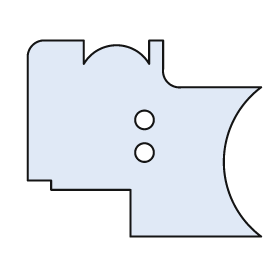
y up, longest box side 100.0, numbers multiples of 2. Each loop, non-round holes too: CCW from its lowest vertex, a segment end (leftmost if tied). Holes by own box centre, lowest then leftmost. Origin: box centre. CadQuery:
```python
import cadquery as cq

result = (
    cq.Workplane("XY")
    .moveTo(-6.0, -42.0)
    .lineTo(50.0, -42.0)
    .threePointArc((34.0, -10.0), (50.0, 22.0))
    .lineTo(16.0, 22.0)
    .threePointArc((10.0, 24.0), (8.0, 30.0))
    .lineTo(8.0, 42.0)
    .lineTo(2.0, 42.0)
    .lineTo(2.0, 32.0)
    .threePointArc((-12.0, 40.0), (-26.0, 32.0))
    .lineTo(-26.0, 42.0)
    .lineTo(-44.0, 42.0)
    .threePointArc((-48.0, 40.0), (-50.0, 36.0))
    .lineTo(-50.0, -18.0)
    .lineTo(-40.0, -18.0)
    .lineTo(-40.0, -22.0)
    .lineTo(-6.0, -22.0)
    .close()
    .moveTo(0.0, -6.0)
    .circle(4.0)
    .moveTo(0.0, 8.0)
    .circle(4.0)
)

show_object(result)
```